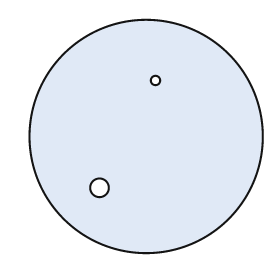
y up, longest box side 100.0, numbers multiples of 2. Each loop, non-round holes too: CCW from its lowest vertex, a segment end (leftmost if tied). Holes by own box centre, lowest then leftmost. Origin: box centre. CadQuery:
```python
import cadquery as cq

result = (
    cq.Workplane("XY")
    .moveTo(0.0, 0.0)
    .circle(50.0)
    .moveTo(-20.0, -22.0)
    .circle(4.0)
    .moveTo(4.0, 24.0)
    .circle(2.0)
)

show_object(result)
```